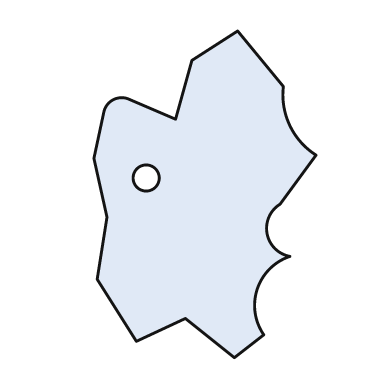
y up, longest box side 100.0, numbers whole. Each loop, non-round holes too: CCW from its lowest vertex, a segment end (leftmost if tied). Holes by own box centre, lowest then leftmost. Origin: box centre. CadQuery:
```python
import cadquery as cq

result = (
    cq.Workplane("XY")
    .moveTo(9.0, -50.0)
    .lineTo(18.0, -43.0)
    .threePointArc((16.0, -29.0), (26.0, -19.0))
    .threePointArc((19.0, -12.0), (23.0, -3.0))
    .lineTo(34.0, 12.0)
    .threePointArc((26.0, 21.0), (24.0, 33.0))
    .lineTo(10.0, 50.0)
    .lineTo(-4.0, 41.0)
    .lineTo(-9.0, 23.0)
    .lineTo(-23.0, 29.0)
    .threePointArc((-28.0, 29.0), (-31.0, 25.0))
    .lineTo(-34.0, 11.0)
    .lineTo(-30.0, -7.0)
    .lineTo(-33.0, -26.0)
    .lineTo(-21.0, -45.0)
    .lineTo(-6.0, -38.0)
    .close()
    .moveTo(-18.0, 5.0)
    .circle(4.0)
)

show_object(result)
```